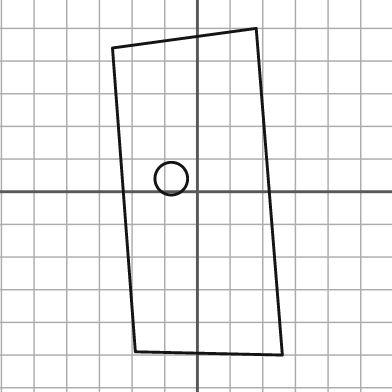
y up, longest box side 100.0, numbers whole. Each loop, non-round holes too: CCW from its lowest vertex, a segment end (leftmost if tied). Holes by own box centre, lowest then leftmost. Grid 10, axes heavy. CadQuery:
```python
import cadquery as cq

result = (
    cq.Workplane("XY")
    .moveTo(26.0, -50.0)
    .lineTo(18.0, 50.0)
    .lineTo(-26.0, 44.0)
    .lineTo(-19.0, -49.0)
    .close()
    .moveTo(-8.0, 4.0)
    .circle(5.0)
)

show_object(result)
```